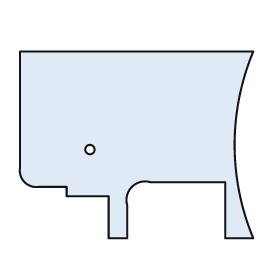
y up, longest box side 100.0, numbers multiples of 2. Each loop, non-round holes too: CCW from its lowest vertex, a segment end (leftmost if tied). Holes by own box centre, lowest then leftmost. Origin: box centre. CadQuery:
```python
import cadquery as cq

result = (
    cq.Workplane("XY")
    .moveTo(-12.0, -40.0)
    .lineTo(-4.0, -40.0)
    .lineTo(-4.0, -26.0)
    .threePointArc((-2.0, -18.0), (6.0, -16.0))
    .lineTo(38.0, -16.0)
    .lineTo(38.0, -40.0)
    .lineTo(50.0, -40.0)
    .threePointArc((42.0, 0.0), (50.0, 40.0))
    .lineTo(-50.0, 40.0)
    .lineTo(-50.0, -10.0)
    .threePointArc((-48.0, -16.0), (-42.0, -18.0))
    .lineTo(-30.0, -18.0)
    .lineTo(-30.0, -22.0)
    .lineTo(-12.0, -22.0)
    .close()
    .moveTo(-20.0, -2.0)
    .circle(2.0)
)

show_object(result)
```